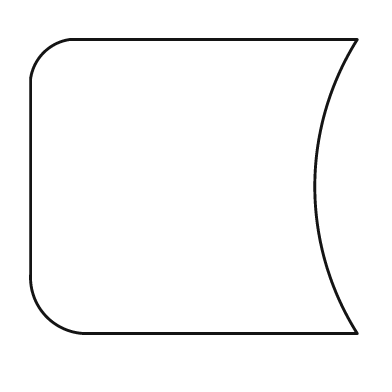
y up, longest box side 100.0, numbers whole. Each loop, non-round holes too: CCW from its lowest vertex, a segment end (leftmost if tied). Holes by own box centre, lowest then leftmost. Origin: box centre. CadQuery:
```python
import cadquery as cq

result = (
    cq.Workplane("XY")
    .moveTo(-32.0, -45.0)
    .lineTo(50.0, -45.0)
    .threePointArc((37.0, 0.0), (50.0, 45.0))
    .lineTo(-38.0, 45.0)
    .threePointArc((-46.0, 41.0), (-50.0, 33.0))
    .lineTo(-50.0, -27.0)
    .threePointArc((-45.0, -40.0), (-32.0, -45.0))
    .close()
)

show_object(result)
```